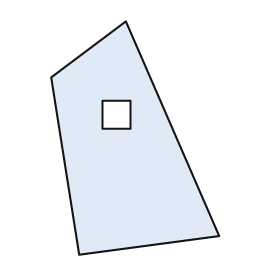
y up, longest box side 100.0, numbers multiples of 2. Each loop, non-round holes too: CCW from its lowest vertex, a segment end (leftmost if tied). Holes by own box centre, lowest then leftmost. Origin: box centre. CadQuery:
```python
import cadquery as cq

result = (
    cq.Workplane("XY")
    .moveTo(-24.0, -50.0)
    .lineTo(36.0, -42.0)
    .lineTo(-4.0, 50.0)
    .lineTo(-36.0, 26.0)
    .close()
    .moveTo(-14.0, 4.0)
    .lineTo(-2.0, 4.0)
    .lineTo(-2.0, 16.0)
    .lineTo(-14.0, 16.0)
    .close()
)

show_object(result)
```